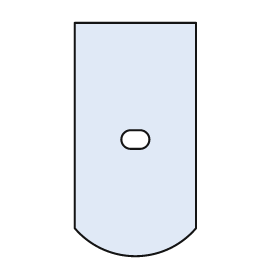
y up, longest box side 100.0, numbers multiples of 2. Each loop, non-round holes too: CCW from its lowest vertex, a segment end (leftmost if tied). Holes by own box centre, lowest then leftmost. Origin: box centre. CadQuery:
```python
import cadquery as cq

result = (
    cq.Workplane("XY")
    .moveTo(-26.0, -38.0)
    .threePointArc((0.0, -50.0), (26.0, -38.0))
    .lineTo(26.0, 50.0)
    .lineTo(-26.0, 50.0)
    .close()
    .moveTo(-2.0, -4.0)
    .lineTo(2.0, -4.0)
    .threePointArc((6.0, 0.0), (2.0, 4.0))
    .lineTo(-2.0, 4.0)
    .threePointArc((-6.0, 0.0), (-2.0, -4.0))
    .close()
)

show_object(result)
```